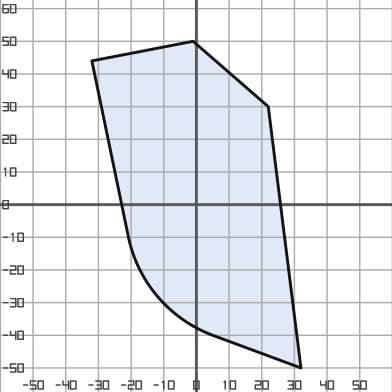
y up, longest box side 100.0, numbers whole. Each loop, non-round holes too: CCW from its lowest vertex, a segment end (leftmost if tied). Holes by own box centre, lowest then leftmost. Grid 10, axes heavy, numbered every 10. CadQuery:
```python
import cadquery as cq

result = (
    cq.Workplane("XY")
    .moveTo(32.0, -50.0)
    .lineTo(22.0, 30.0)
    .lineTo(-1.0, 50.0)
    .lineTo(-32.0, 44.0)
    .lineTo(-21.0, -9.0)
    .threePointArc((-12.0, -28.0), (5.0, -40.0))
    .close()
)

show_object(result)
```